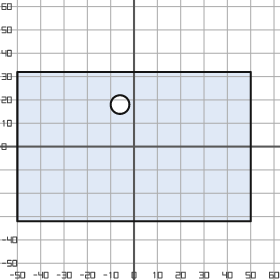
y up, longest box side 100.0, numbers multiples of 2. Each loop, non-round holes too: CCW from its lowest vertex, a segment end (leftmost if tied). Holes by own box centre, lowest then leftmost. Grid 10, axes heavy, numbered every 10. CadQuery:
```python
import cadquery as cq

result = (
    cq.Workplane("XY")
    .moveTo(-50.0, -32.0)
    .lineTo(50.0, -32.0)
    .lineTo(50.0, 32.0)
    .lineTo(-50.0, 32.0)
    .close()
    .moveTo(-6.0, 18.0)
    .circle(4.0)
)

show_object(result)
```